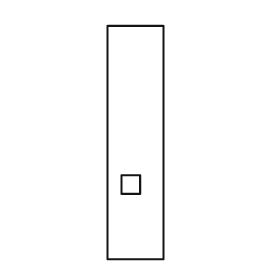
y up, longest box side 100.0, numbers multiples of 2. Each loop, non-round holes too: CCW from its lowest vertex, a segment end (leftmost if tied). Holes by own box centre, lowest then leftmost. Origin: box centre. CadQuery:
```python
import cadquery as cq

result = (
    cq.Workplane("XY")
    .moveTo(-12.0, -50.0)
    .lineTo(12.0, -50.0)
    .lineTo(12.0, 50.0)
    .lineTo(-12.0, 50.0)
    .close()
    .moveTo(-6.0, -22.0)
    .lineTo(2.0, -22.0)
    .lineTo(2.0, -14.0)
    .lineTo(-6.0, -14.0)
    .close()
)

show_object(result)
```